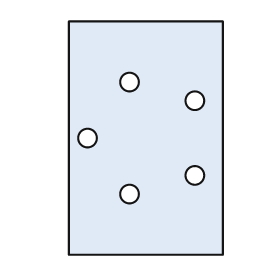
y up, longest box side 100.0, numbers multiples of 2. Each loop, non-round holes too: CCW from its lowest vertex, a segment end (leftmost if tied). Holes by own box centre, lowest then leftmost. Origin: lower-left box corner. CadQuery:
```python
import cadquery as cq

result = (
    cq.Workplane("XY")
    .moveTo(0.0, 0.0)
    .lineTo(66.0, 0.0)
    .lineTo(66.0, 100.0)
    .lineTo(0.0, 100.0)
    .close()
    .moveTo(26.0, 26.0)
    .circle(4.0)
    .moveTo(54.0, 34.0)
    .circle(4.0)
    .moveTo(8.0, 50.0)
    .circle(4.0)
    .moveTo(54.0, 66.0)
    .circle(4.0)
    .moveTo(26.0, 74.0)
    .circle(4.0)
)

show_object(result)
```